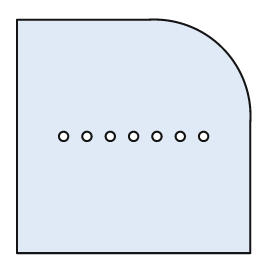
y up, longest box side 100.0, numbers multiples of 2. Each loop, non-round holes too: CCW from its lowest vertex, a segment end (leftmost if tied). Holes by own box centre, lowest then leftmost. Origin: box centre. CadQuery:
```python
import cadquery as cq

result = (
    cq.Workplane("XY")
    .moveTo(-50.0, -50.0)
    .lineTo(50.0, -50.0)
    .lineTo(50.0, 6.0)
    .threePointArc((38.0, 38.0), (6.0, 50.0))
    .lineTo(-50.0, 50.0)
    .close()
    .moveTo(-30.0, 0.0)
    .circle(2.0)
    .moveTo(-20.0, 0.0)
    .circle(2.0)
    .moveTo(-10.0, 0.0)
    .circle(2.0)
    .moveTo(0.0, 0.0)
    .circle(2.0)
    .moveTo(10.0, 0.0)
    .circle(2.0)
    .moveTo(20.0, 0.0)
    .circle(2.0)
    .moveTo(30.0, 0.0)
    .circle(2.0)
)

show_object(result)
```